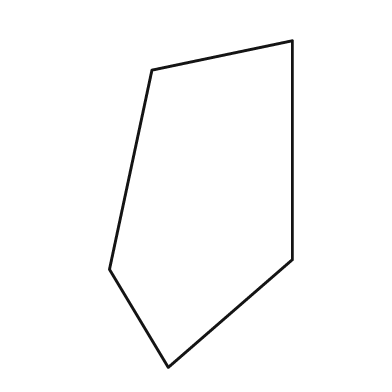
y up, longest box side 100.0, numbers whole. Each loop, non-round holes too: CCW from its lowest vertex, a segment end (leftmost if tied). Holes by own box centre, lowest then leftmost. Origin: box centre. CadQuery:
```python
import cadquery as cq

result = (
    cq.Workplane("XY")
    .moveTo(-10.0, -50.0)
    .lineTo(28.0, -17.0)
    .lineTo(28.0, 50.0)
    .lineTo(-15.0, 41.0)
    .lineTo(-28.0, -20.0)
    .close()
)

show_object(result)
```